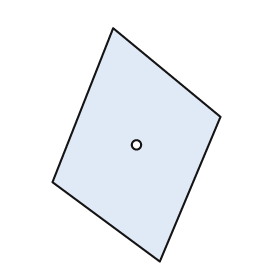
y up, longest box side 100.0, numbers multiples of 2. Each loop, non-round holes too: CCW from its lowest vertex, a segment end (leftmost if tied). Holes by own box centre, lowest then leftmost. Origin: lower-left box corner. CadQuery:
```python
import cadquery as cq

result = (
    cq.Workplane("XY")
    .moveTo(46.0, 0.0)
    .lineTo(72.0, 62.0)
    .lineTo(26.0, 100.0)
    .lineTo(0.0, 34.0)
    .close()
    .moveTo(36.0, 50.0)
    .circle(2.0)
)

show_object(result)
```